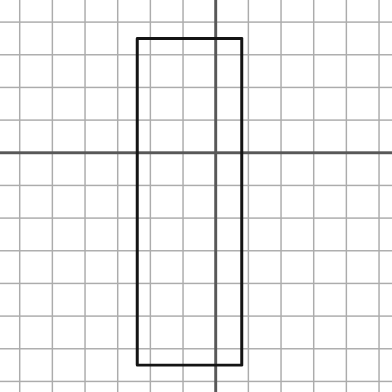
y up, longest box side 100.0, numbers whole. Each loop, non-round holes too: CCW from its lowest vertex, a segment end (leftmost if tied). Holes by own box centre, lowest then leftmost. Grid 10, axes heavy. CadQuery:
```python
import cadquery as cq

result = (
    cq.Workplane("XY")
    .moveTo(-24.0, -65.0)
    .lineTo(8.0, -65.0)
    .lineTo(8.0, 35.0)
    .lineTo(-24.0, 35.0)
    .close()
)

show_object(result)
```